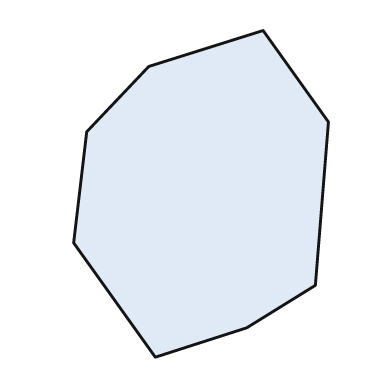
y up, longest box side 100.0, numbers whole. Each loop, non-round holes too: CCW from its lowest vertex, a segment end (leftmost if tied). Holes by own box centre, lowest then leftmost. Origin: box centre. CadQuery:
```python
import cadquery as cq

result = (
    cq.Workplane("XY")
    .moveTo(-14.0, -50.0)
    .lineTo(14.0, -41.0)
    .lineTo(35.0, -28.0)
    .lineTo(39.0, 22.0)
    .lineTo(19.0, 50.0)
    .lineTo(-16.0, 39.0)
    .lineTo(-35.0, 19.0)
    .lineTo(-39.0, -15.0)
    .close()
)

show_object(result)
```